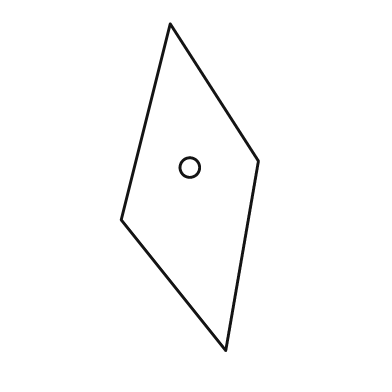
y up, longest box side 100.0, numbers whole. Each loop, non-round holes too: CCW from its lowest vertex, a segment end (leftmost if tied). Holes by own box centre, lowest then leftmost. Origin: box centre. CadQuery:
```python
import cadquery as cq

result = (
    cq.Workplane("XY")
    .moveTo(11.0, -50.0)
    .lineTo(21.0, 8.0)
    .lineTo(-6.0, 50.0)
    .lineTo(-21.0, -10.0)
    .close()
    .moveTo(0.0, 6.0)
    .circle(3.0)
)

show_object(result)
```